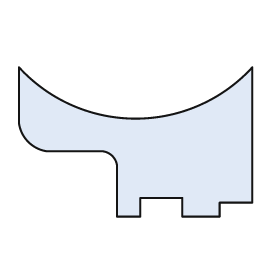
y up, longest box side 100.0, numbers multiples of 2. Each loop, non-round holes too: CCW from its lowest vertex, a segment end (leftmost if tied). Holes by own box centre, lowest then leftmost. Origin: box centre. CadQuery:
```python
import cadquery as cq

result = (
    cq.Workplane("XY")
    .moveTo(-8.0, -32.0)
    .lineTo(2.0, -32.0)
    .lineTo(2.0, -24.0)
    .lineTo(20.0, -24.0)
    .lineTo(20.0, -32.0)
    .lineTo(36.0, -32.0)
    .lineTo(36.0, -26.0)
    .lineTo(50.0, -26.0)
    .lineTo(50.0, 32.0)
    .threePointArc((0.0, 10.0), (-50.0, 32.0))
    .lineTo(-50.0, 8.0)
    .threePointArc((-46.0, 0.0), (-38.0, -4.0))
    .lineTo(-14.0, -4.0)
    .threePointArc((-10.0, -6.0), (-8.0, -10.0))
    .close()
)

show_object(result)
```